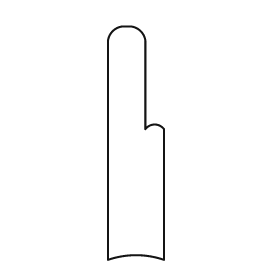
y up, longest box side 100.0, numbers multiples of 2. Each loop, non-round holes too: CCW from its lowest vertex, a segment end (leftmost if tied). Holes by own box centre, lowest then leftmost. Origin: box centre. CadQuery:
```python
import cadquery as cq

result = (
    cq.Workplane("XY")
    .moveTo(-12.0, -50.0)
    .threePointArc((0.0, -48.0), (12.0, -50.0))
    .lineTo(12.0, 6.0)
    .threePointArc((8.0, 8.0), (4.0, 6.0))
    .lineTo(4.0, 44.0)
    .threePointArc((2.0, 48.0), (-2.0, 50.0))
    .lineTo(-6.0, 50.0)
    .threePointArc((-10.0, 48.0), (-12.0, 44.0))
    .close()
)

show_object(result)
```